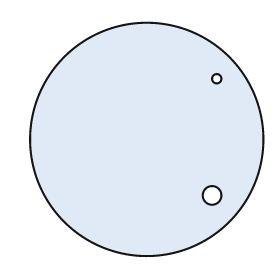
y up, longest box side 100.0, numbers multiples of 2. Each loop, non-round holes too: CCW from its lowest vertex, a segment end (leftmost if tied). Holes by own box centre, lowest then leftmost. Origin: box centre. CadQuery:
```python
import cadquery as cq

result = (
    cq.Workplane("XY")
    .moveTo(0.0, 0.0)
    .circle(50.0)
    .moveTo(28.0, -24.0)
    .circle(4.0)
    .moveTo(30.0, 26.0)
    .circle(2.0)
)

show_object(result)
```